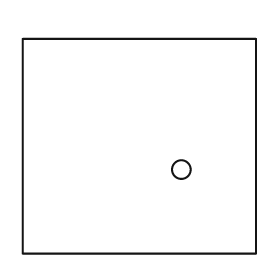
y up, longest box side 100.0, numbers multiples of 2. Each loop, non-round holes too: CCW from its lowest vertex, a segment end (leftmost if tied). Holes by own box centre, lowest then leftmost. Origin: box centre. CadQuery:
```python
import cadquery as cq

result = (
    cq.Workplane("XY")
    .moveTo(-50.0, -46.0)
    .lineTo(50.0, -46.0)
    .lineTo(50.0, 46.0)
    .lineTo(-50.0, 46.0)
    .close()
    .moveTo(18.0, -10.0)
    .circle(4.0)
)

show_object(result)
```